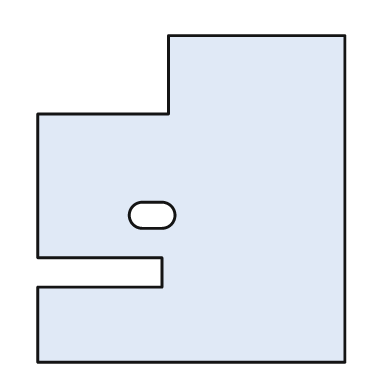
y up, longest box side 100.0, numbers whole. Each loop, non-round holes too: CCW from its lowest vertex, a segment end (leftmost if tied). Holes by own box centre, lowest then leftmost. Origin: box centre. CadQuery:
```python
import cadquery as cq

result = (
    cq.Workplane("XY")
    .moveTo(-47.0, -50.0)
    .lineTo(47.0, -50.0)
    .lineTo(47.0, 50.0)
    .lineTo(-7.0, 50.0)
    .lineTo(-7.0, 26.0)
    .lineTo(-47.0, 26.0)
    .lineTo(-47.0, -18.0)
    .lineTo(-9.0, -18.0)
    .lineTo(-9.0, -27.0)
    .lineTo(-47.0, -27.0)
    .close()
    .moveTo(-15.0, -9.0)
    .lineTo(-9.0, -9.0)
    .threePointArc((-5.0, -5.0), (-9.0, -1.0))
    .lineTo(-15.0, -1.0)
    .threePointArc((-19.0, -5.0), (-15.0, -9.0))
    .close()
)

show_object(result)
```